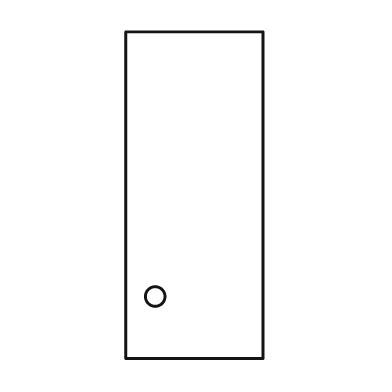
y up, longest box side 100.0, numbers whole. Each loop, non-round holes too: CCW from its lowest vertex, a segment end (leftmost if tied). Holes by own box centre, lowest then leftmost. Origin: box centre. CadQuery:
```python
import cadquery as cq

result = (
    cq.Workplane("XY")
    .moveTo(-21.0, -50.0)
    .lineTo(21.0, -50.0)
    .lineTo(21.0, 50.0)
    .lineTo(-21.0, 50.0)
    .close()
    .moveTo(-12.0, -31.0)
    .circle(3.0)
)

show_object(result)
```